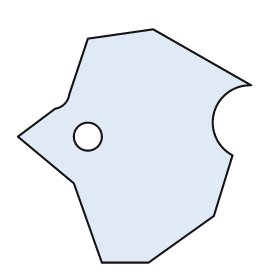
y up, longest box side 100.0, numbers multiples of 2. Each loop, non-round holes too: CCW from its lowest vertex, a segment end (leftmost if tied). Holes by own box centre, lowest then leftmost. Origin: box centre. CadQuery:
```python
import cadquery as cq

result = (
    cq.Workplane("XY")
    .moveTo(-14.0, -50.0)
    .lineTo(6.0, -50.0)
    .lineTo(34.0, -30.0)
    .lineTo(42.0, -4.0)
    .threePointArc((34.0, 14.0), (50.0, 26.0))
    .lineTo(8.0, 50.0)
    .lineTo(-20.0, 46.0)
    .lineTo(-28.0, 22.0)
    .threePointArc((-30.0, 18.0), (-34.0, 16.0))
    .lineTo(-50.0, 4.0)
    .lineTo(-26.0, -16.0)
    .close()
    .moveTo(-20.0, 4.0)
    .circle(6.0)
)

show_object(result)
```